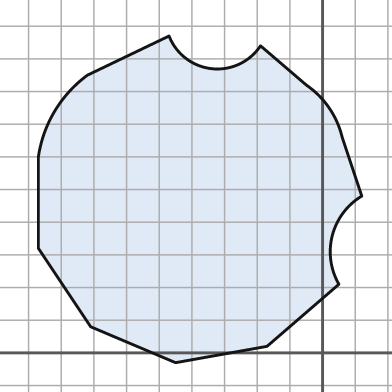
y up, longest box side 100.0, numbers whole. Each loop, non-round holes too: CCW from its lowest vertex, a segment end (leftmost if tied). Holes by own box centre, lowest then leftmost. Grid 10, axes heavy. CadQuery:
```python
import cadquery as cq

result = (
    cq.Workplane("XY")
    .moveTo(-45.0, -3.0)
    .lineTo(-17.0, 2.0)
    .lineTo(5.0, 21.0)
    .threePointArc((3.0, 36.0), (12.0, 48.0))
    .lineTo(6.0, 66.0)
    .threePointArc((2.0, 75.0), (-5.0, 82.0))
    .lineTo(-19.0, 94.0)
    .threePointArc((-34.0, 87.0), (-47.0, 97.0))
    .lineTo(-72.0, 85.0)
    .threePointArc((-82.0, 74.0), (-87.0, 60.0))
    .lineTo(-87.0, 32.0)
    .lineTo(-71.0, 8.0)
    .close()
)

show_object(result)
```